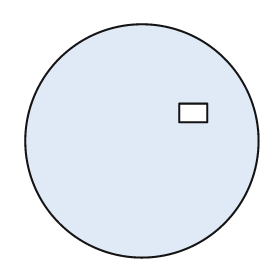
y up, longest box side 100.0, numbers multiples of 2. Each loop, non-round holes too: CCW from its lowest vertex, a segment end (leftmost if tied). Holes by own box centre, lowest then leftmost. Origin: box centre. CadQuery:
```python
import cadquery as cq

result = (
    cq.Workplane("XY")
    .moveTo(0.0, 0.0)
    .circle(50.0)
    .moveTo(16.0, 8.0)
    .lineTo(28.0, 8.0)
    .lineTo(28.0, 16.0)
    .lineTo(16.0, 16.0)
    .close()
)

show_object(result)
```